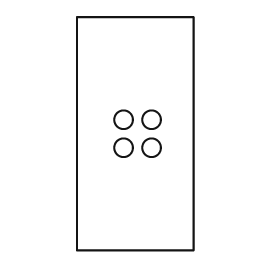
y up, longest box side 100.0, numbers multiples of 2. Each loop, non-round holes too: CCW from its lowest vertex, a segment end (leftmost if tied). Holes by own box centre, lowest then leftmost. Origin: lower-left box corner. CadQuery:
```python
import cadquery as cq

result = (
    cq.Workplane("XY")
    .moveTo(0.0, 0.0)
    .lineTo(50.0, 0.0)
    .lineTo(50.0, 100.0)
    .lineTo(0.0, 100.0)
    .close()
    .moveTo(20.0, 44.0)
    .circle(4.0)
    .moveTo(32.0, 44.0)
    .circle(4.0)
    .moveTo(20.0, 56.0)
    .circle(4.0)
    .moveTo(32.0, 56.0)
    .circle(4.0)
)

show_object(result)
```